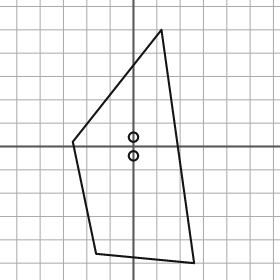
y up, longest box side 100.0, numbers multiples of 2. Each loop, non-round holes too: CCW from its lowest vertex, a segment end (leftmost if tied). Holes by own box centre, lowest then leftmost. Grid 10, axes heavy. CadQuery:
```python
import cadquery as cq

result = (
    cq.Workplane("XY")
    .moveTo(26.0, -50.0)
    .lineTo(12.0, 50.0)
    .lineTo(-26.0, 2.0)
    .lineTo(-16.0, -46.0)
    .close()
    .moveTo(0.0, -4.0)
    .circle(2.0)
    .moveTo(0.0, 4.0)
    .circle(2.0)
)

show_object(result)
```